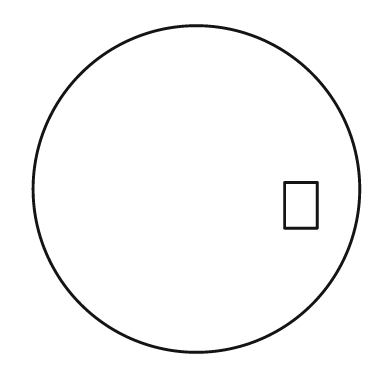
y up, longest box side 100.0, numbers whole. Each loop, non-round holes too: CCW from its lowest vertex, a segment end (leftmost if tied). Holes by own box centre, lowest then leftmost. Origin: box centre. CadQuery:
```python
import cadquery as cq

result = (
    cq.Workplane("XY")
    .moveTo(0.0, 0.0)
    .circle(50.0)
    .moveTo(27.0, -12.0)
    .lineTo(37.0, -12.0)
    .lineTo(37.0, 2.0)
    .lineTo(27.0, 2.0)
    .close()
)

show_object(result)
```